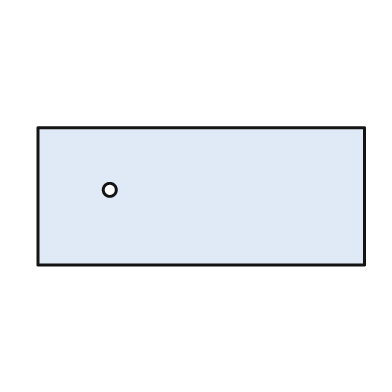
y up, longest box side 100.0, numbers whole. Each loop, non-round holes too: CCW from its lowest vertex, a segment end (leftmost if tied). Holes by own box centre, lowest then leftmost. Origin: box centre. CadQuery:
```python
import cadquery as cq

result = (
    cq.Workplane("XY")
    .moveTo(-50.0, -21.0)
    .lineTo(50.0, -21.0)
    .lineTo(50.0, 21.0)
    .lineTo(-50.0, 21.0)
    .close()
    .moveTo(-28.0, 2.0)
    .circle(2.0)
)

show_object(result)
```